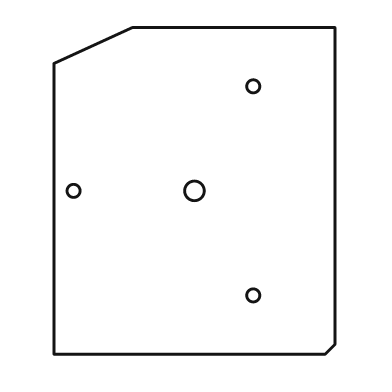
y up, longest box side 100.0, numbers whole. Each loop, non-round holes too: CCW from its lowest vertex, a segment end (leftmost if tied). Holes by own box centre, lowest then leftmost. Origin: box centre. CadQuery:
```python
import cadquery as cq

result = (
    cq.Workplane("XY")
    .moveTo(-43.0, -50.0)
    .lineTo(40.0, -50.0)
    .lineTo(43.0, -47.0)
    .lineTo(43.0, 50.0)
    .lineTo(-19.0, 50.0)
    .lineTo(-43.0, 39.0)
    .close()
    .moveTo(18.0, -32.0)
    .circle(2.0)
    .moveTo(-37.0, 0.0)
    .circle(2.0)
    .moveTo(0.0, 0.0)
    .circle(3.0)
    .moveTo(18.0, 32.0)
    .circle(2.0)
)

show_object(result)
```